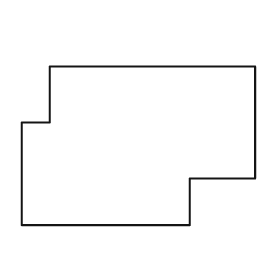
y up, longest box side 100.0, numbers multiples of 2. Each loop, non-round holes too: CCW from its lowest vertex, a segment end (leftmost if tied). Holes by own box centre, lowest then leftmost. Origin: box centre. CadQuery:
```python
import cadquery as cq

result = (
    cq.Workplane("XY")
    .moveTo(-50.0, -34.0)
    .lineTo(22.0, -34.0)
    .lineTo(22.0, -14.0)
    .lineTo(50.0, -14.0)
    .lineTo(50.0, 34.0)
    .lineTo(-38.0, 34.0)
    .lineTo(-38.0, 10.0)
    .lineTo(-50.0, 10.0)
    .close()
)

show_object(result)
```